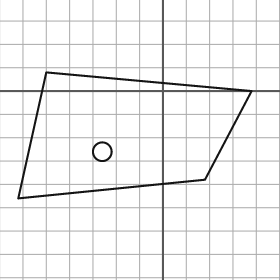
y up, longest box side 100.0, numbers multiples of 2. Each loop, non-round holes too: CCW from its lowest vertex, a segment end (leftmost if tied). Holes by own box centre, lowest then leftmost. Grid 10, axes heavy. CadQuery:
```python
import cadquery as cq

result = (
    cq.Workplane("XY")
    .moveTo(-62.0, -46.0)
    .lineTo(18.0, -38.0)
    .lineTo(38.0, 0.0)
    .lineTo(-50.0, 8.0)
    .close()
    .moveTo(-26.0, -26.0)
    .circle(4.0)
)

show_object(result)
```